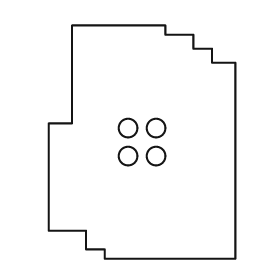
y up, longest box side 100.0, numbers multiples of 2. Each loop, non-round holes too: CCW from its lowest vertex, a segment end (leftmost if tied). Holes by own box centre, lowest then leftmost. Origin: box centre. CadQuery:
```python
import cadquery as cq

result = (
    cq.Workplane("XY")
    .moveTo(-16.0, -50.0)
    .lineTo(40.0, -50.0)
    .lineTo(40.0, 34.0)
    .lineTo(30.0, 34.0)
    .lineTo(30.0, 40.0)
    .lineTo(22.0, 40.0)
    .lineTo(22.0, 46.0)
    .lineTo(10.0, 46.0)
    .lineTo(10.0, 50.0)
    .lineTo(-30.0, 50.0)
    .lineTo(-30.0, 8.0)
    .lineTo(-40.0, 8.0)
    .lineTo(-40.0, -38.0)
    .lineTo(-24.0, -38.0)
    .lineTo(-24.0, -46.0)
    .lineTo(-16.0, -46.0)
    .close()
    .moveTo(-6.0, -6.0)
    .circle(4.0)
    .moveTo(6.0, -6.0)
    .circle(4.0)
    .moveTo(-6.0, 6.0)
    .circle(4.0)
    .moveTo(6.0, 6.0)
    .circle(4.0)
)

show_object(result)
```